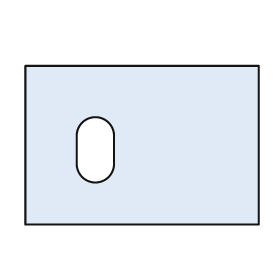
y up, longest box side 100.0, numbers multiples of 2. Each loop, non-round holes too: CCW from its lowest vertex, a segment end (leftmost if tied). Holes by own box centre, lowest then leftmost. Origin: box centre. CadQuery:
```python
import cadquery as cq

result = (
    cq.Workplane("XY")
    .moveTo(-50.0, -34.0)
    .lineTo(50.0, -34.0)
    .lineTo(50.0, 34.0)
    .lineTo(-50.0, 34.0)
    .close()
    .moveTo(-28.0, -8.0)
    .threePointArc((-20.0, -16.0), (-12.0, -8.0))
    .lineTo(-12.0, 4.0)
    .threePointArc((-20.0, 12.0), (-28.0, 4.0))
    .close()
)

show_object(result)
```